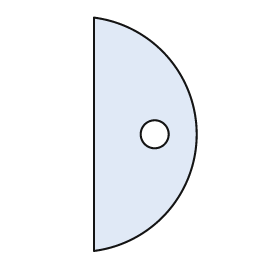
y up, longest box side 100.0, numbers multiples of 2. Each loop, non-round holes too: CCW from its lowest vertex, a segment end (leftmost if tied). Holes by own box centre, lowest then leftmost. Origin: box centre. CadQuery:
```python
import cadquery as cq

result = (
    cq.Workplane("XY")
    .moveTo(-22.0, -50.0)
    .threePointArc((22.0, 0.0), (-22.0, 50.0))
    .close()
    .moveTo(4.0, 0.0)
    .circle(6.0)
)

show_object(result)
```